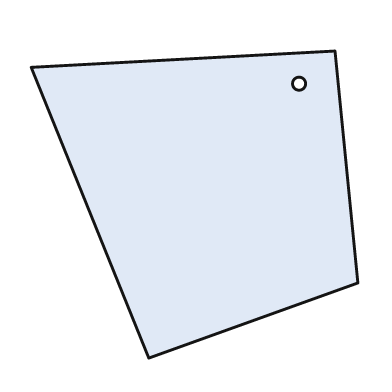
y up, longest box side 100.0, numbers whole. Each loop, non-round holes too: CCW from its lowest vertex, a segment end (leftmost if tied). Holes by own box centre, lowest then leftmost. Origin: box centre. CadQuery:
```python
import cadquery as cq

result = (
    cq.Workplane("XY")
    .moveTo(-14.0, -47.0)
    .lineTo(50.0, -24.0)
    .lineTo(43.0, 47.0)
    .lineTo(-50.0, 42.0)
    .close()
    .moveTo(32.0, 37.0)
    .circle(2.0)
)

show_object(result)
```